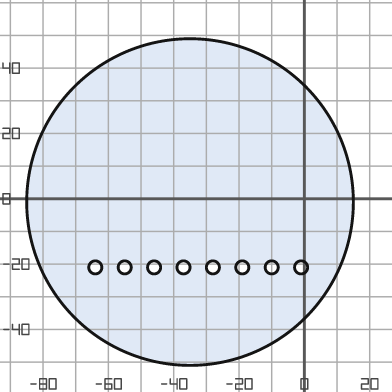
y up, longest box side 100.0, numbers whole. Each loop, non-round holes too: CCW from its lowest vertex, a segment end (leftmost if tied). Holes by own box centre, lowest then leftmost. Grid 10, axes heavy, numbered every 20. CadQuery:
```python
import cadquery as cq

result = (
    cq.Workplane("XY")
    .moveTo(-35.0, -1.0)
    .circle(50.0)
    .moveTo(-64.0, -21.0)
    .circle(2.0)
    .moveTo(-55.0, -21.0)
    .circle(2.0)
    .moveTo(-46.0, -21.0)
    .circle(2.0)
    .moveTo(-37.0, -21.0)
    .circle(2.0)
    .moveTo(-28.0, -21.0)
    .circle(2.0)
    .moveTo(-19.0, -21.0)
    .circle(2.0)
    .moveTo(-10.0, -21.0)
    .circle(2.0)
    .moveTo(-1.0, -21.0)
    .circle(2.0)
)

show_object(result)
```